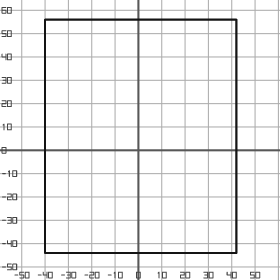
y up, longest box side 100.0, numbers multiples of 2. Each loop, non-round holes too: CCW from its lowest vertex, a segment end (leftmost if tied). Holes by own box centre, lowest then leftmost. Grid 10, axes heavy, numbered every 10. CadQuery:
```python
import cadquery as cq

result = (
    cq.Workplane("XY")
    .moveTo(-40.0, -44.0)
    .lineTo(42.0, -44.0)
    .lineTo(42.0, 56.0)
    .lineTo(-40.0, 56.0)
    .close()
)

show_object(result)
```